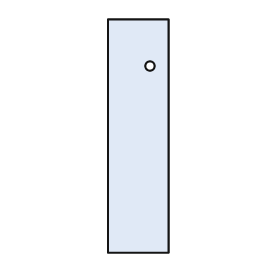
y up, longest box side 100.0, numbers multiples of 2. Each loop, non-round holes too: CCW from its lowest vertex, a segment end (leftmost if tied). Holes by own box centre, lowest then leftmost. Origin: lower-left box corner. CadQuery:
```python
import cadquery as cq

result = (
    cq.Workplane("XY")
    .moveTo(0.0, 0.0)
    .lineTo(26.0, 0.0)
    .lineTo(26.0, 100.0)
    .lineTo(0.0, 100.0)
    .close()
    .moveTo(18.0, 80.0)
    .circle(2.0)
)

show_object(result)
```